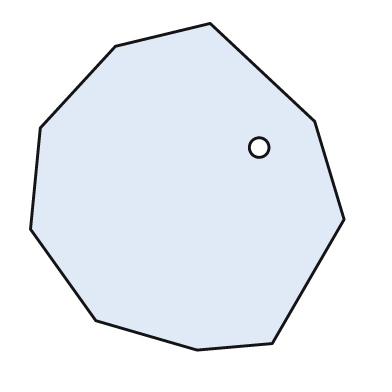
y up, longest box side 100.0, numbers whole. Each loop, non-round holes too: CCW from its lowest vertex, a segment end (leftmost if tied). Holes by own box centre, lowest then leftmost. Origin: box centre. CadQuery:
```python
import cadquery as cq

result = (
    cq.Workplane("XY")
    .moveTo(3.0, -50.0)
    .lineTo(26.0, -48.0)
    .lineTo(48.0, -10.0)
    .lineTo(39.0, 20.0)
    .lineTo(7.0, 50.0)
    .lineTo(-22.0, 43.0)
    .lineTo(-45.0, 18.0)
    .lineTo(-48.0, -13.0)
    .lineTo(-28.0, -41.0)
    .close()
    .moveTo(22.0, 12.0)
    .circle(3.0)
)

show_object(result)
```